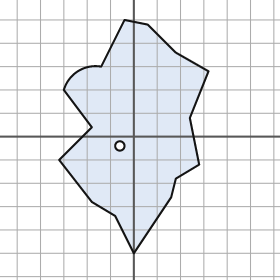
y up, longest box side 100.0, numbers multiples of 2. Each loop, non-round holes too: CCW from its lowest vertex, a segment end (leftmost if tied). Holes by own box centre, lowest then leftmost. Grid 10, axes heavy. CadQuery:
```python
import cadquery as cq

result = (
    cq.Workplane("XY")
    .moveTo(0.0, -50.0)
    .lineTo(16.0, -26.0)
    .lineTo(18.0, -18.0)
    .lineTo(28.0, -12.0)
    .lineTo(24.0, 8.0)
    .lineTo(32.0, 28.0)
    .lineTo(18.0, 36.0)
    .lineTo(6.0, 48.0)
    .lineTo(-4.0, 50.0)
    .lineTo(-14.0, 30.0)
    .threePointArc((-24.0, 28.0), (-30.0, 20.0))
    .lineTo(-18.0, 4.0)
    .lineTo(-32.0, -10.0)
    .lineTo(-18.0, -28.0)
    .lineTo(-8.0, -34.0)
    .close()
    .moveTo(-6.0, -4.0)
    .circle(2.0)
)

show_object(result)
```